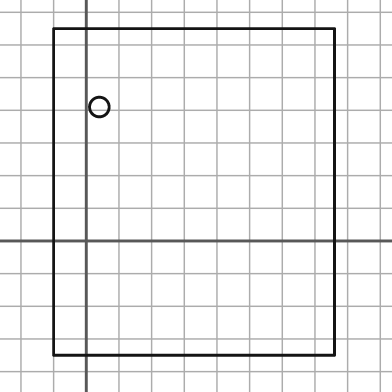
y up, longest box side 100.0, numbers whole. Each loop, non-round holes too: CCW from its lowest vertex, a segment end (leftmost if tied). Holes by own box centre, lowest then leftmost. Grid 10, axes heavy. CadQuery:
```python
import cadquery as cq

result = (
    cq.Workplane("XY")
    .moveTo(-10.0, -35.0)
    .lineTo(76.0, -35.0)
    .lineTo(76.0, 65.0)
    .lineTo(-10.0, 65.0)
    .close()
    .moveTo(4.0, 41.0)
    .circle(3.0)
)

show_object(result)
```